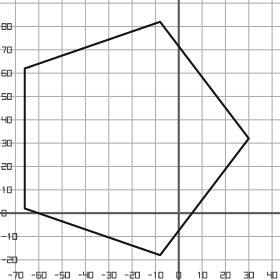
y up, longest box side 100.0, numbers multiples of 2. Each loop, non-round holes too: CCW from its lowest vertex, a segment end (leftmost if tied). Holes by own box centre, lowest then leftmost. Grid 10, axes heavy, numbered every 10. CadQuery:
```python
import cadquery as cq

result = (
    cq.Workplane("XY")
    .moveTo(-8.0, -18.0)
    .lineTo(30.0, 32.0)
    .lineTo(-8.0, 82.0)
    .lineTo(-66.0, 62.0)
    .lineTo(-66.0, 2.0)
    .close()
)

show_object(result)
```